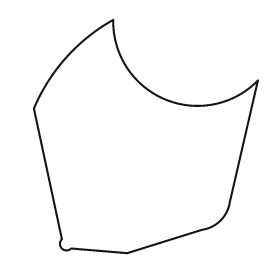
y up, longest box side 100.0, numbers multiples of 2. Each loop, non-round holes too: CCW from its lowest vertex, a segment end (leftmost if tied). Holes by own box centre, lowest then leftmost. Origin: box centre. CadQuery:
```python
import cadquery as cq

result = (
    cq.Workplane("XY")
    .moveTo(-8.0, -50.0)
    .lineTo(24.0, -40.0)
    .threePointArc((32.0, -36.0), (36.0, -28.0))
    .lineTo(48.0, 24.0)
    .threePointArc((8.0, 16.0), (-14.0, 50.0))
    .threePointArc((-34.0, 34.0), (-48.0, 12.0))
    .lineTo(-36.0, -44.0)
    .threePointArc((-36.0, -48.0), (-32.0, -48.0))
    .close()
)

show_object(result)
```